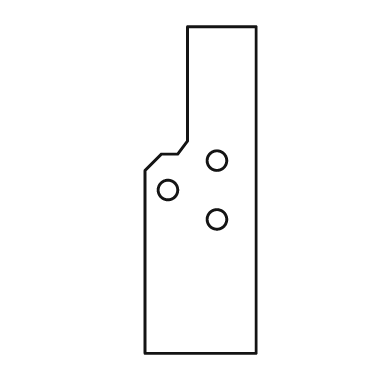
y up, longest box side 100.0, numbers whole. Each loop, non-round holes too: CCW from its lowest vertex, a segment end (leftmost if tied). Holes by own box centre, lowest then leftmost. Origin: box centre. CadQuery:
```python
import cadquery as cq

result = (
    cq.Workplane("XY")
    .moveTo(-17.0, -50.0)
    .lineTo(17.0, -50.0)
    .lineTo(17.0, 50.0)
    .lineTo(-4.0, 50.0)
    .lineTo(-4.0, 15.0)
    .lineTo(-7.0, 11.0)
    .lineTo(-12.0, 11.0)
    .lineTo(-17.0, 6.0)
    .close()
    .moveTo(5.0, -9.0)
    .circle(3.0)
    .moveTo(-10.0, 0.0)
    .circle(3.0)
    .moveTo(5.0, 9.0)
    .circle(3.0)
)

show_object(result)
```